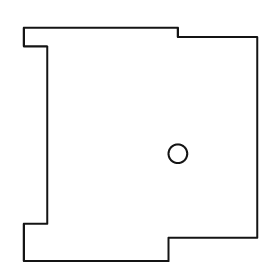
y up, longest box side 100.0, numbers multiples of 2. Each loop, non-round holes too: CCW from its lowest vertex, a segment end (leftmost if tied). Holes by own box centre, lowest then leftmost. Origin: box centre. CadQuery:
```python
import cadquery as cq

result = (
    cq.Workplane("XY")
    .moveTo(-50.0, -50.0)
    .lineTo(12.0, -50.0)
    .lineTo(12.0, -40.0)
    .lineTo(50.0, -40.0)
    .lineTo(50.0, 46.0)
    .lineTo(16.0, 46.0)
    .lineTo(16.0, 50.0)
    .lineTo(-50.0, 50.0)
    .lineTo(-50.0, 42.0)
    .lineTo(-40.0, 42.0)
    .lineTo(-40.0, -34.0)
    .lineTo(-50.0, -34.0)
    .close()
    .moveTo(16.0, -4.0)
    .circle(4.0)
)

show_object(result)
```